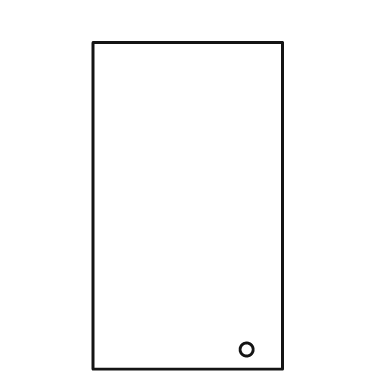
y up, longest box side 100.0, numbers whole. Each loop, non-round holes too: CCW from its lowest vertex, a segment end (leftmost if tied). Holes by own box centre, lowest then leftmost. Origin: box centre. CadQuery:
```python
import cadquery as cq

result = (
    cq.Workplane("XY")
    .moveTo(-29.0, -50.0)
    .lineTo(29.0, -50.0)
    .lineTo(29.0, 50.0)
    .lineTo(-29.0, 50.0)
    .close()
    .moveTo(18.0, -44.0)
    .circle(2.0)
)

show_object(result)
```